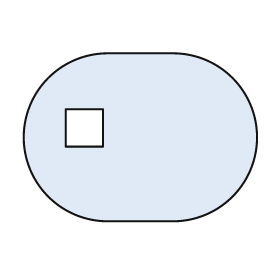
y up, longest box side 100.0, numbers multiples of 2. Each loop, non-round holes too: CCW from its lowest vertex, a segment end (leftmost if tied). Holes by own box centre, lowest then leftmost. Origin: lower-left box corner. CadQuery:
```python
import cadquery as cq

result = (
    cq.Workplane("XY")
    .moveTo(36.0, 0.0)
    .lineTo(64.0, 0.0)
    .threePointArc((100.0, 36.0), (64.0, 72.0))
    .lineTo(36.0, 72.0)
    .threePointArc((0.0, 36.0), (36.0, 0.0))
    .close()
    .moveTo(18.0, 32.0)
    .lineTo(34.0, 32.0)
    .lineTo(34.0, 48.0)
    .lineTo(18.0, 48.0)
    .close()
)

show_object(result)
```